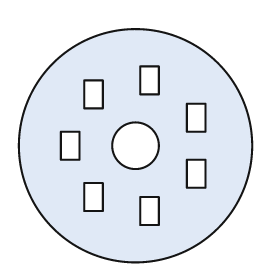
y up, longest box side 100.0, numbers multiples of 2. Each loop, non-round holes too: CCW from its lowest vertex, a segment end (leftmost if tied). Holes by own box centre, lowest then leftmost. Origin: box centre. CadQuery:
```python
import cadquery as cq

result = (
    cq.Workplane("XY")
    .moveTo(0.0, 0.0)
    .circle(50.0)
    .moveTo(2.0, -34.0)
    .lineTo(10.0, -34.0)
    .lineTo(10.0, -22.0)
    .lineTo(2.0, -22.0)
    .close()
    .moveTo(-22.0, -28.0)
    .lineTo(-14.0, -28.0)
    .lineTo(-14.0, -16.0)
    .lineTo(-22.0, -16.0)
    .close()
    .moveTo(22.0, -18.0)
    .lineTo(30.0, -18.0)
    .lineTo(30.0, -6.0)
    .lineTo(22.0, -6.0)
    .close()
    .moveTo(-32.0, -6.0)
    .lineTo(-24.0, -6.0)
    .lineTo(-24.0, 6.0)
    .lineTo(-32.0, 6.0)
    .close()
    .moveTo(0.0, 0.0)
    .circle(10.0)
    .moveTo(22.0, 6.0)
    .lineTo(30.0, 6.0)
    .lineTo(30.0, 18.0)
    .lineTo(22.0, 18.0)
    .close()
    .moveTo(-22.0, 16.0)
    .lineTo(-14.0, 16.0)
    .lineTo(-14.0, 28.0)
    .lineTo(-22.0, 28.0)
    .close()
    .moveTo(2.0, 22.0)
    .lineTo(10.0, 22.0)
    .lineTo(10.0, 34.0)
    .lineTo(2.0, 34.0)
    .close()
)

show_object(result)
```